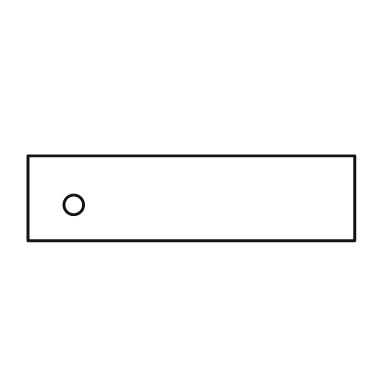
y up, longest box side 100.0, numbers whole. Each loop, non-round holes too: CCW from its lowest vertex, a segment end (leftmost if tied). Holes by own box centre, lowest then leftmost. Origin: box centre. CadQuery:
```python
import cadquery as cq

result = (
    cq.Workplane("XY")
    .moveTo(-50.0, -13.0)
    .lineTo(50.0, -13.0)
    .lineTo(50.0, 13.0)
    .lineTo(-50.0, 13.0)
    .close()
    .moveTo(-36.0, -2.0)
    .circle(3.0)
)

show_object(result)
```